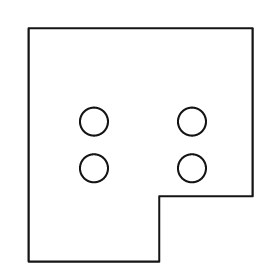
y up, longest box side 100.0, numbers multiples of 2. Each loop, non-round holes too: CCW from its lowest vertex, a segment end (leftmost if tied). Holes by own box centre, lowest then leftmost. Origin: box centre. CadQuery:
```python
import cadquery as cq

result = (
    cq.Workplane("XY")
    .moveTo(-48.0, -50.0)
    .lineTo(8.0, -50.0)
    .lineTo(8.0, -22.0)
    .lineTo(48.0, -22.0)
    .lineTo(48.0, 50.0)
    .lineTo(-48.0, 50.0)
    .close()
    .moveTo(-20.0, -10.0)
    .circle(6.0)
    .moveTo(22.0, -10.0)
    .circle(6.0)
    .moveTo(-20.0, 10.0)
    .circle(6.0)
    .moveTo(22.0, 10.0)
    .circle(6.0)
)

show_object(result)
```